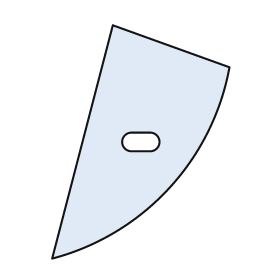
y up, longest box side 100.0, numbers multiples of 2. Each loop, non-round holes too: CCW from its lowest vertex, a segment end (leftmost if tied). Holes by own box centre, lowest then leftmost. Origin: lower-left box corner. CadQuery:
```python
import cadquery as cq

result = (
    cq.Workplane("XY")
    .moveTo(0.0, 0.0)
    .threePointArc((50.0, 30.0), (76.0, 82.0))
    .lineTo(26.0, 100.0)
    .close()
    .moveTo(34.0, 46.0)
    .lineTo(42.0, 46.0)
    .threePointArc((46.0, 50.0), (42.0, 54.0))
    .lineTo(34.0, 54.0)
    .threePointArc((30.0, 50.0), (34.0, 46.0))
    .close()
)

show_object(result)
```